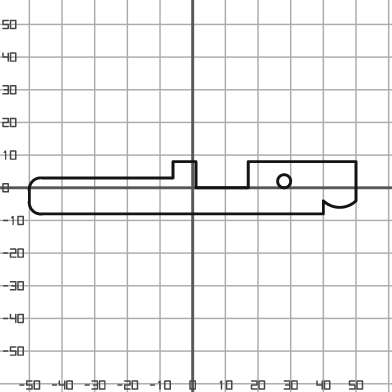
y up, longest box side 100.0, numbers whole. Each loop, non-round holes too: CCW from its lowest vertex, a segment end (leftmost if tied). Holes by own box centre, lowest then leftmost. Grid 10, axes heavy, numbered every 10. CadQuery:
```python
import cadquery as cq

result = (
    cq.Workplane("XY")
    .moveTo(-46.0, -8.0)
    .lineTo(40.0, -8.0)
    .lineTo(40.0, -4.0)
    .threePointArc((45.0, -6.0), (50.0, -4.0))
    .lineTo(50.0, 8.0)
    .lineTo(17.0, 8.0)
    .lineTo(17.0, 0.0)
    .lineTo(1.0, 0.0)
    .lineTo(1.0, 8.0)
    .lineTo(-6.0, 8.0)
    .lineTo(-6.0, 3.0)
    .lineTo(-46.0, 3.0)
    .threePointArc((-49.0, 2.0), (-50.0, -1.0))
    .lineTo(-50.0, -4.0)
    .threePointArc((-49.0, -7.0), (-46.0, -8.0))
    .close()
    .moveTo(28.0, 2.0)
    .circle(2.0)
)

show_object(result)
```